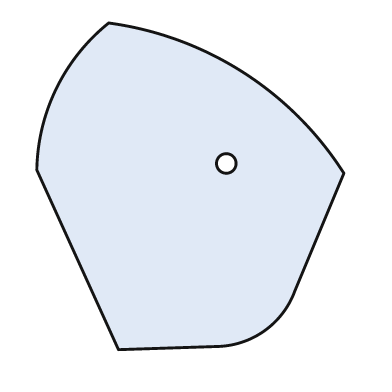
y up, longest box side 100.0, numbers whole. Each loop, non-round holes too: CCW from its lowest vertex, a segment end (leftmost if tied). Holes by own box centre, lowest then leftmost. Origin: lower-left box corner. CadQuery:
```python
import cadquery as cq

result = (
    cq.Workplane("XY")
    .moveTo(25.0, 0.0)
    .lineTo(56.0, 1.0)
    .threePointArc((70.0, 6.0), (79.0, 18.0))
    .lineTo(94.0, 54.0)
    .threePointArc((63.0, 85.0), (22.0, 100.0))
    .threePointArc((6.0, 80.0), (0.0, 55.0))
    .close()
    .moveTo(58.0, 57.0)
    .circle(3.0)
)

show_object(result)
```